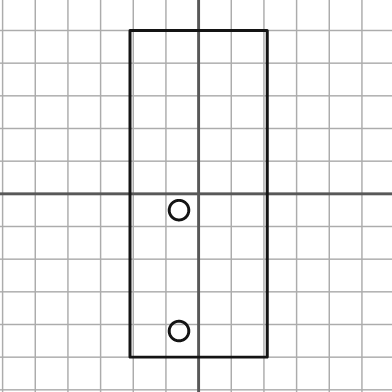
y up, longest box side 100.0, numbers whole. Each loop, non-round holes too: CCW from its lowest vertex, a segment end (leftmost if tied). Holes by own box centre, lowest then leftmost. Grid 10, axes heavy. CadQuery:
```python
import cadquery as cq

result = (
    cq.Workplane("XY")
    .moveTo(-21.0, -50.0)
    .lineTo(21.0, -50.0)
    .lineTo(21.0, 50.0)
    .lineTo(-21.0, 50.0)
    .close()
    .moveTo(-6.0, -42.0)
    .circle(3.0)
    .moveTo(-6.0, -5.0)
    .circle(3.0)
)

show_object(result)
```